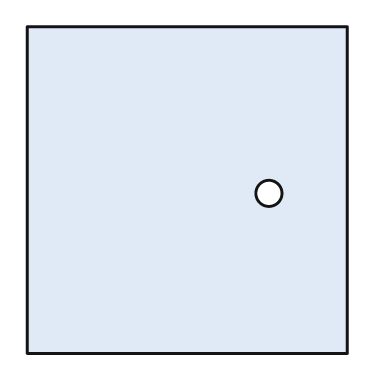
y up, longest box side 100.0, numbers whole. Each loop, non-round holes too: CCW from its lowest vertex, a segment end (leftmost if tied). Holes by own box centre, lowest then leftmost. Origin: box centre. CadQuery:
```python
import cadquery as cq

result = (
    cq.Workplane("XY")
    .moveTo(-49.0, -50.0)
    .lineTo(49.0, -50.0)
    .lineTo(49.0, 50.0)
    .lineTo(-49.0, 50.0)
    .close()
    .moveTo(25.0, -1.0)
    .circle(4.0)
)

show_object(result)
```